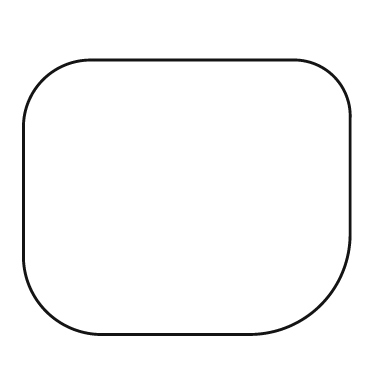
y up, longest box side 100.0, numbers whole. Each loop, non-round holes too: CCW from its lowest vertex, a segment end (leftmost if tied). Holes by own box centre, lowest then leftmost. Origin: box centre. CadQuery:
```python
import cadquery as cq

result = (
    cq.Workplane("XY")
    .moveTo(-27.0, -42.0)
    .lineTo(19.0, -42.0)
    .threePointArc((41.0, -33.0), (50.0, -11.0))
    .lineTo(50.0, 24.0)
    .threePointArc((45.0, 37.0), (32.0, 42.0))
    .lineTo(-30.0, 42.0)
    .threePointArc((-44.0, 36.0), (-50.0, 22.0))
    .lineTo(-50.0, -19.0)
    .threePointArc((-43.0, -35.0), (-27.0, -42.0))
    .close()
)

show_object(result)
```